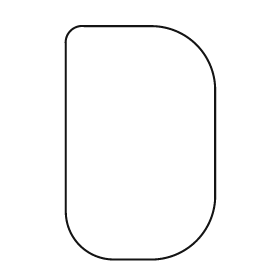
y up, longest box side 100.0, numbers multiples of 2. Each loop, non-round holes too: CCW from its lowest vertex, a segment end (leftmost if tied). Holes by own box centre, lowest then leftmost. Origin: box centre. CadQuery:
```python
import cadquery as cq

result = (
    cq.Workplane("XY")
    .moveTo(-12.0, -50.0)
    .lineTo(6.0, -50.0)
    .threePointArc((24.0, -42.0), (32.0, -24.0))
    .lineTo(32.0, 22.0)
    .threePointArc((24.0, 42.0), (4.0, 50.0))
    .lineTo(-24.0, 50.0)
    .threePointArc((-30.0, 48.0), (-32.0, 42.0))
    .lineTo(-32.0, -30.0)
    .threePointArc((-26.0, -44.0), (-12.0, -50.0))
    .close()
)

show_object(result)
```